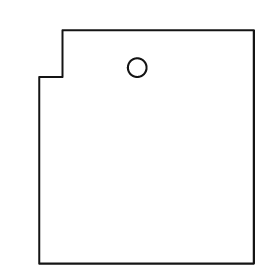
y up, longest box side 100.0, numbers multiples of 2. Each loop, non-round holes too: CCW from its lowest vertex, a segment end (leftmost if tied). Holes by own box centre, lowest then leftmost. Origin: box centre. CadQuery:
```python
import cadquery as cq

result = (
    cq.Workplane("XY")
    .moveTo(-46.0, -50.0)
    .lineTo(46.0, -50.0)
    .lineTo(46.0, 50.0)
    .lineTo(-36.0, 50.0)
    .lineTo(-36.0, 30.0)
    .lineTo(-46.0, 30.0)
    .close()
    .moveTo(-4.0, 34.0)
    .circle(4.0)
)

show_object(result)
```